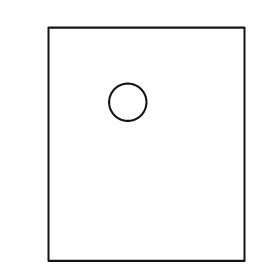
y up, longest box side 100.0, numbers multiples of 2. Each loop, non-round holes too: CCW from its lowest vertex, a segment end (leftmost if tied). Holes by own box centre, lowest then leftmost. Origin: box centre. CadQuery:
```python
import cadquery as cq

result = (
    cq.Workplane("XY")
    .moveTo(-42.0, -50.0)
    .lineTo(42.0, -50.0)
    .lineTo(42.0, 50.0)
    .lineTo(-42.0, 50.0)
    .close()
    .moveTo(-8.0, 18.0)
    .circle(8.0)
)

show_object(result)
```